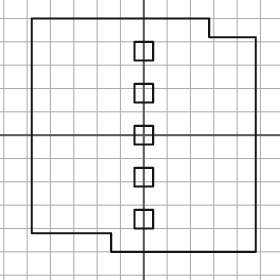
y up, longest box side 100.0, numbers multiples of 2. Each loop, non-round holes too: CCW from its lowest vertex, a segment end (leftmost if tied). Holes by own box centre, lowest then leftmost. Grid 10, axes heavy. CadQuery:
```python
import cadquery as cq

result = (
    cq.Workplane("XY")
    .moveTo(-14.0, -50.0)
    .lineTo(48.0, -50.0)
    .lineTo(48.0, 42.0)
    .lineTo(28.0, 42.0)
    .lineTo(28.0, 50.0)
    .lineTo(-48.0, 50.0)
    .lineTo(-48.0, -42.0)
    .lineTo(-14.0, -42.0)
    .close()
    .moveTo(-4.0, -40.0)
    .lineTo(4.0, -40.0)
    .lineTo(4.0, -32.0)
    .lineTo(-4.0, -32.0)
    .close()
    .moveTo(-4.0, -22.0)
    .lineTo(4.0, -22.0)
    .lineTo(4.0, -14.0)
    .lineTo(-4.0, -14.0)
    .close()
    .moveTo(-4.0, -4.0)
    .lineTo(4.0, -4.0)
    .lineTo(4.0, 4.0)
    .lineTo(-4.0, 4.0)
    .close()
    .moveTo(-4.0, 14.0)
    .lineTo(4.0, 14.0)
    .lineTo(4.0, 22.0)
    .lineTo(-4.0, 22.0)
    .close()
    .moveTo(-4.0, 32.0)
    .lineTo(4.0, 32.0)
    .lineTo(4.0, 40.0)
    .lineTo(-4.0, 40.0)
    .close()
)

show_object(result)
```